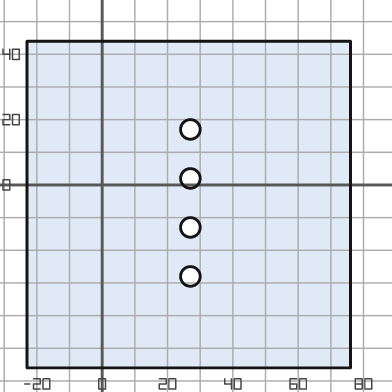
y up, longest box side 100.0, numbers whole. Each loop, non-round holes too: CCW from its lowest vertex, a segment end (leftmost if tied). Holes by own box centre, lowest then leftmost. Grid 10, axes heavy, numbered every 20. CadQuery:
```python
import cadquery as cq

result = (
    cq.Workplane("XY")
    .moveTo(-23.0, -56.0)
    .lineTo(76.0, -56.0)
    .lineTo(76.0, 44.0)
    .lineTo(-23.0, 44.0)
    .close()
    .moveTo(27.0, -28.0)
    .circle(3.0)
    .moveTo(27.0, -13.0)
    .circle(3.0)
    .moveTo(27.0, 2.0)
    .circle(3.0)
    .moveTo(27.0, 17.0)
    .circle(3.0)
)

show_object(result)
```